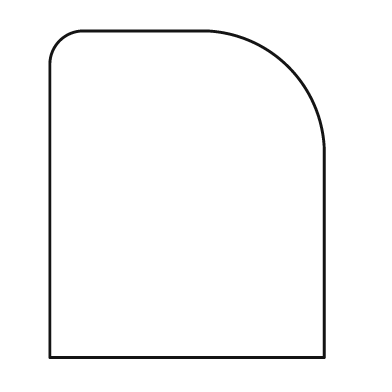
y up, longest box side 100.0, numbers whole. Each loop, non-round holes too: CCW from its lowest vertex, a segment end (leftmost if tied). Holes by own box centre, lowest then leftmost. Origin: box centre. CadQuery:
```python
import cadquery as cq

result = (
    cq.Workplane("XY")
    .moveTo(-42.0, -50.0)
    .lineTo(42.0, -50.0)
    .lineTo(42.0, 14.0)
    .threePointArc((31.0, 39.0), (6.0, 50.0))
    .lineTo(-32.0, 50.0)
    .threePointArc((-39.0, 47.0), (-42.0, 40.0))
    .close()
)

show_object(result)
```